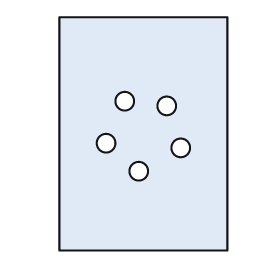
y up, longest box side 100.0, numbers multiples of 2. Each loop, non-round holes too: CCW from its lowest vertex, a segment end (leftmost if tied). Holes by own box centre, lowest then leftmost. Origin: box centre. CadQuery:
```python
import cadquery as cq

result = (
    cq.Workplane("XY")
    .moveTo(-36.0, -50.0)
    .lineTo(36.0, -50.0)
    .lineTo(36.0, 50.0)
    .lineTo(-36.0, 50.0)
    .close()
    .moveTo(-2.0, -16.0)
    .circle(4.0)
    .moveTo(16.0, -6.0)
    .circle(4.0)
    .moveTo(-16.0, -4.0)
    .circle(4.0)
    .moveTo(10.0, 12.0)
    .circle(4.0)
    .moveTo(-8.0, 14.0)
    .circle(4.0)
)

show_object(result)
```